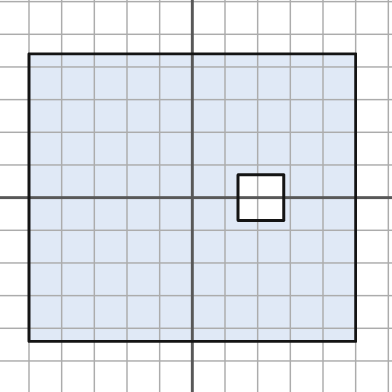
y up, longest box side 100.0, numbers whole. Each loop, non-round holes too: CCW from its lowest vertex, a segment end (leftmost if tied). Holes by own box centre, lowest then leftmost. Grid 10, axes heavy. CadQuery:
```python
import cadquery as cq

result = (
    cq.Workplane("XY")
    .moveTo(-50.0, -44.0)
    .lineTo(50.0, -44.0)
    .lineTo(50.0, 44.0)
    .lineTo(-50.0, 44.0)
    .close()
    .moveTo(14.0, -7.0)
    .lineTo(28.0, -7.0)
    .lineTo(28.0, 7.0)
    .lineTo(14.0, 7.0)
    .close()
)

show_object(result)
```